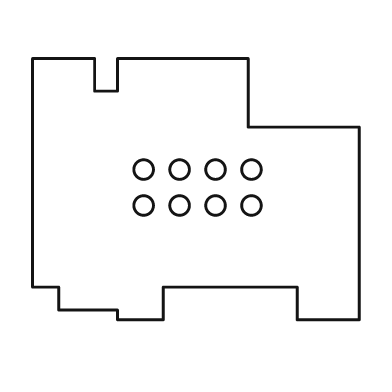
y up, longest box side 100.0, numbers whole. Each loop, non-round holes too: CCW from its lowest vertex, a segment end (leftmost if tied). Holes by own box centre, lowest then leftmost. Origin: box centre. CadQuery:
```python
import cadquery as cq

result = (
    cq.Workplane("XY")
    .moveTo(-24.0, -40.0)
    .lineTo(-10.0, -40.0)
    .lineTo(-10.0, -30.0)
    .lineTo(31.0, -30.0)
    .lineTo(31.0, -40.0)
    .lineTo(50.0, -40.0)
    .lineTo(50.0, 19.0)
    .lineTo(16.0, 19.0)
    .lineTo(16.0, 40.0)
    .lineTo(-24.0, 40.0)
    .lineTo(-24.0, 30.0)
    .lineTo(-31.0, 30.0)
    .lineTo(-31.0, 40.0)
    .lineTo(-50.0, 40.0)
    .lineTo(-50.0, -30.0)
    .lineTo(-42.0, -30.0)
    .lineTo(-42.0, -37.0)
    .lineTo(-24.0, -37.0)
    .close()
    .moveTo(-16.0, -5.0)
    .circle(3.0)
    .moveTo(-5.0, -5.0)
    .circle(3.0)
    .moveTo(6.0, -5.0)
    .circle(3.0)
    .moveTo(17.0, -5.0)
    .circle(3.0)
    .moveTo(-16.0, 6.0)
    .circle(3.0)
    .moveTo(-5.0, 6.0)
    .circle(3.0)
    .moveTo(6.0, 6.0)
    .circle(3.0)
    .moveTo(17.0, 6.0)
    .circle(3.0)
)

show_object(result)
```